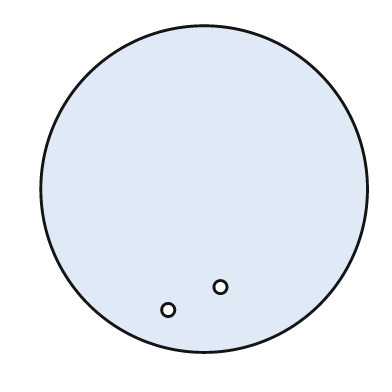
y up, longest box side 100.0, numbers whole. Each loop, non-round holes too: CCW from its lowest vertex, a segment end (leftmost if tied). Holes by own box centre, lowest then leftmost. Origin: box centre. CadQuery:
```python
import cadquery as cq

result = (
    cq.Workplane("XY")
    .moveTo(0.0, 0.0)
    .circle(50.0)
    .moveTo(-11.0, -37.0)
    .circle(2.0)
    .moveTo(5.0, -30.0)
    .circle(2.0)
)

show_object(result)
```